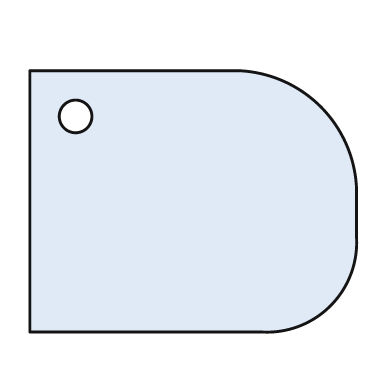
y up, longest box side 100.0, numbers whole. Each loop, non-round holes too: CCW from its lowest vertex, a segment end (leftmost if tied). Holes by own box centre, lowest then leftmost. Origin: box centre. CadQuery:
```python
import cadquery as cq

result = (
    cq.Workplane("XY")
    .moveTo(-50.0, -40.0)
    .lineTo(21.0, -40.0)
    .threePointArc((42.0, -32.0), (50.0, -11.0))
    .lineTo(50.0, 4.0)
    .threePointArc((39.0, 29.0), (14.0, 40.0))
    .lineTo(-50.0, 40.0)
    .close()
    .moveTo(-36.0, 26.0)
    .circle(5.0)
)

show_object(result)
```